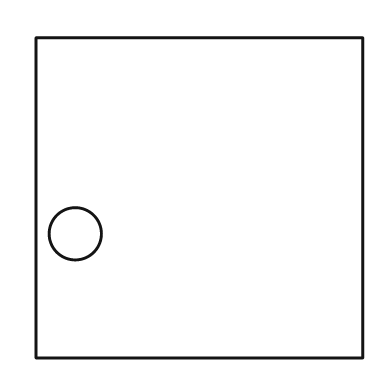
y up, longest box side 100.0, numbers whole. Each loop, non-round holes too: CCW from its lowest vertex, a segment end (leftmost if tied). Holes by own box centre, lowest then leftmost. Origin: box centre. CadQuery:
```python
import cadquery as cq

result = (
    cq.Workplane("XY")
    .moveTo(-50.0, -49.0)
    .lineTo(50.0, -49.0)
    .lineTo(50.0, 49.0)
    .lineTo(-50.0, 49.0)
    .close()
    .moveTo(-38.0, -11.0)
    .circle(8.0)
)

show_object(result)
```